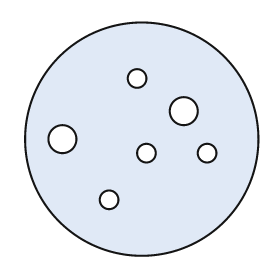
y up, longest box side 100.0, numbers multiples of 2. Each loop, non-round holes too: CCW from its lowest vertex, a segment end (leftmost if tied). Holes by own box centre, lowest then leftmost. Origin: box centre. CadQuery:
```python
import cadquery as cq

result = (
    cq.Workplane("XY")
    .moveTo(0.0, 0.0)
    .circle(50.0)
    .moveTo(-14.0, -26.0)
    .circle(4.0)
    .moveTo(2.0, -6.0)
    .circle(4.0)
    .moveTo(28.0, -6.0)
    .circle(4.0)
    .moveTo(-34.0, 0.0)
    .circle(6.0)
    .moveTo(18.0, 12.0)
    .circle(6.0)
    .moveTo(-2.0, 26.0)
    .circle(4.0)
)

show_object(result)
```